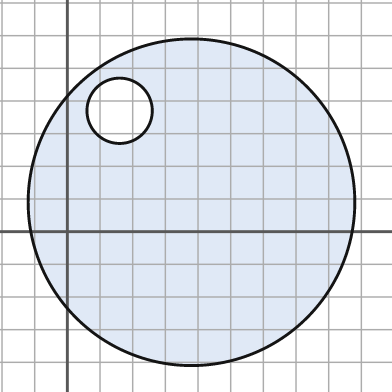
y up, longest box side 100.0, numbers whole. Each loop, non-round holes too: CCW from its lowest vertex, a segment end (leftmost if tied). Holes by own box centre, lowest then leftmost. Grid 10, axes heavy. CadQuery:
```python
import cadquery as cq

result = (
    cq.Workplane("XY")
    .moveTo(38.0, 9.0)
    .circle(50.0)
    .moveTo(16.0, 37.0)
    .circle(10.0)
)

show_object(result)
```